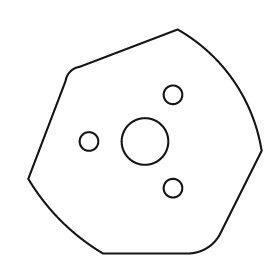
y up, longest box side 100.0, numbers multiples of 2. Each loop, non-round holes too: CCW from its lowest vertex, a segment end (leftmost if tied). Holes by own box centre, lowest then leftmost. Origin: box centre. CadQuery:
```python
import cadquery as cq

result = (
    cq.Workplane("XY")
    .moveTo(-18.0, -48.0)
    .lineTo(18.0, -48.0)
    .threePointArc((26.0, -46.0), (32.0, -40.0))
    .lineTo(50.0, -4.0)
    .threePointArc((38.0, 26.0), (14.0, 48.0))
    .lineTo(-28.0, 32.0)
    .threePointArc((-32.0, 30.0), (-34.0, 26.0))
    .lineTo(-50.0, -16.0)
    .threePointArc((-36.0, -34.0), (-18.0, -48.0))
    .close()
    .moveTo(12.0, -20.0)
    .circle(4.0)
    .moveTo(-24.0, 0.0)
    .circle(4.0)
    .moveTo(0.0, 0.0)
    .circle(10.0)
    .moveTo(12.0, 20.0)
    .circle(4.0)
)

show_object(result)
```